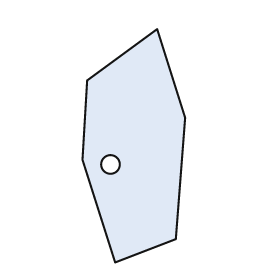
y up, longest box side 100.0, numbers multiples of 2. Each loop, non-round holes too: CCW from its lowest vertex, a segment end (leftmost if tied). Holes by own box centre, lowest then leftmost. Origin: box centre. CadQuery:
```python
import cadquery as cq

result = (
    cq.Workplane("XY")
    .moveTo(-8.0, -50.0)
    .lineTo(18.0, -40.0)
    .lineTo(22.0, 12.0)
    .lineTo(10.0, 50.0)
    .lineTo(-20.0, 28.0)
    .lineTo(-22.0, -6.0)
    .close()
    .moveTo(-10.0, -8.0)
    .circle(4.0)
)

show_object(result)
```